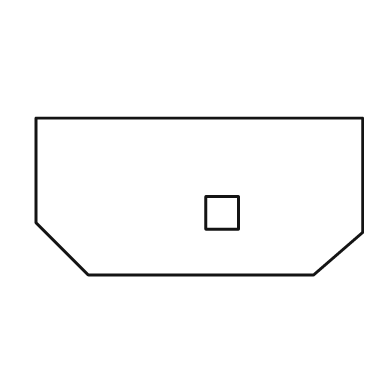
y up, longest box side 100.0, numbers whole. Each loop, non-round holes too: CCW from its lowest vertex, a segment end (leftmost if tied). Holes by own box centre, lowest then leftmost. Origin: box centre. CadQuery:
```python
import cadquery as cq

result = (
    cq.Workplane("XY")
    .moveTo(-34.0, -24.0)
    .lineTo(35.0, -24.0)
    .lineTo(50.0, -11.0)
    .lineTo(50.0, 24.0)
    .lineTo(-50.0, 24.0)
    .lineTo(-50.0, -8.0)
    .close()
    .moveTo(2.0, -10.0)
    .lineTo(12.0, -10.0)
    .lineTo(12.0, 0.0)
    .lineTo(2.0, 0.0)
    .close()
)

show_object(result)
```